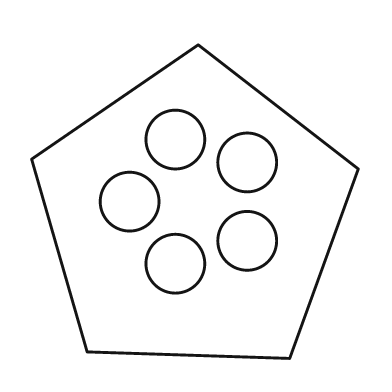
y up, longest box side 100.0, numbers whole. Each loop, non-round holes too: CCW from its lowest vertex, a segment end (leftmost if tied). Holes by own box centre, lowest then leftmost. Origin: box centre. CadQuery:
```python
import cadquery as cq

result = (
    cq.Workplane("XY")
    .moveTo(29.0, -48.0)
    .lineTo(50.0, 10.0)
    .lineTo(1.0, 48.0)
    .lineTo(-50.0, 13.0)
    .lineTo(-33.0, -46.0)
    .close()
    .moveTo(-6.0, -19.0)
    .circle(9.0)
    .moveTo(16.0, -12.0)
    .circle(9.0)
    .moveTo(-20.0, 0.0)
    .circle(9.0)
    .moveTo(16.0, 12.0)
    .circle(9.0)
    .moveTo(-6.0, 19.0)
    .circle(9.0)
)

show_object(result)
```